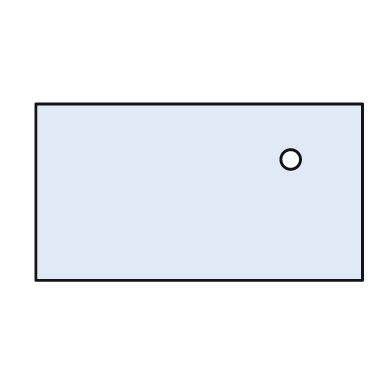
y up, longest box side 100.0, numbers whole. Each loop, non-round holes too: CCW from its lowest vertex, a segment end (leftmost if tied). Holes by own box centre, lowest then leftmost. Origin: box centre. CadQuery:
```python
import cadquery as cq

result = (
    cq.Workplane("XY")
    .moveTo(-50.0, -27.0)
    .lineTo(50.0, -27.0)
    .lineTo(50.0, 27.0)
    .lineTo(-50.0, 27.0)
    .close()
    .moveTo(28.0, 10.0)
    .circle(3.0)
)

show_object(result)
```